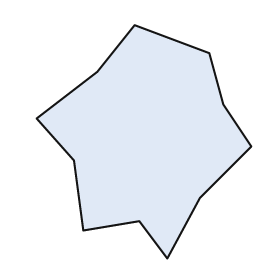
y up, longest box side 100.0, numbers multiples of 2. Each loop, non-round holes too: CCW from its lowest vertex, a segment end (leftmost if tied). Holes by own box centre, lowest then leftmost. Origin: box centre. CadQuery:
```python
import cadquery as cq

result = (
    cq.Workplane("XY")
    .moveTo(10.0, -50.0)
    .lineTo(24.0, -24.0)
    .lineTo(46.0, -2.0)
    .lineTo(34.0, 16.0)
    .lineTo(28.0, 38.0)
    .lineTo(-4.0, 50.0)
    .lineTo(-20.0, 30.0)
    .lineTo(-46.0, 10.0)
    .lineTo(-30.0, -8.0)
    .lineTo(-26.0, -38.0)
    .lineTo(-2.0, -34.0)
    .close()
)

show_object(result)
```